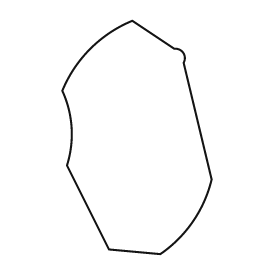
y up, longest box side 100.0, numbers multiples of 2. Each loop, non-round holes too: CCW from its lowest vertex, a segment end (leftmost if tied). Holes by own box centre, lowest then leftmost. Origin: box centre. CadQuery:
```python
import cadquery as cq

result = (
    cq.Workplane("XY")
    .moveTo(10.0, -50.0)
    .threePointArc((24.0, -36.0), (32.0, -18.0))
    .lineTo(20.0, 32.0)
    .threePointArc((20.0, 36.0), (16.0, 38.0))
    .lineTo(-2.0, 50.0)
    .threePointArc((-20.0, 38.0), (-32.0, 20.0))
    .threePointArc((-28.0, 4.0), (-30.0, -12.0))
    .lineTo(-12.0, -48.0)
    .close()
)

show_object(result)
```